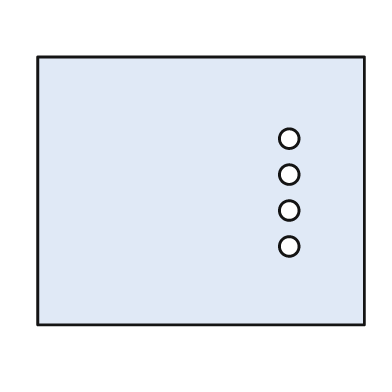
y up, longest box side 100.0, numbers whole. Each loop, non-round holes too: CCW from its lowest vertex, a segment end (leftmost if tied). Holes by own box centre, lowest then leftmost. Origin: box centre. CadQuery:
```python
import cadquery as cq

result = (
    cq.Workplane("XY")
    .moveTo(-50.0, -41.0)
    .lineTo(50.0, -41.0)
    .lineTo(50.0, 41.0)
    .lineTo(-50.0, 41.0)
    .close()
    .moveTo(27.0, -17.0)
    .circle(3.0)
    .moveTo(27.0, -6.0)
    .circle(3.0)
    .moveTo(27.0, 5.0)
    .circle(3.0)
    .moveTo(27.0, 16.0)
    .circle(3.0)
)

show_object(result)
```